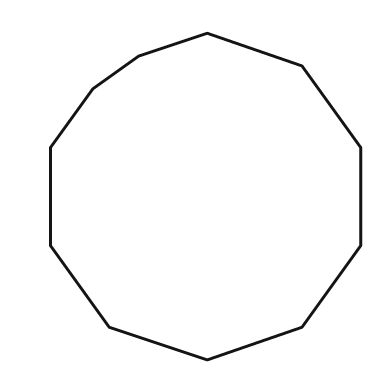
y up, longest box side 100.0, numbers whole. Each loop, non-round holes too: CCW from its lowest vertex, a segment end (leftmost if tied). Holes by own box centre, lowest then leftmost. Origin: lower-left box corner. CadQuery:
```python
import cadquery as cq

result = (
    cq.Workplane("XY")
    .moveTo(48.0, 0.0)
    .lineTo(77.0, 10.0)
    .lineTo(95.0, 35.0)
    .lineTo(95.0, 65.0)
    .lineTo(77.0, 90.0)
    .lineTo(48.0, 100.0)
    .lineTo(27.0, 93.0)
    .lineTo(13.0, 83.0)
    .lineTo(0.0, 65.0)
    .lineTo(0.0, 35.0)
    .lineTo(18.0, 10.0)
    .close()
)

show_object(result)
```